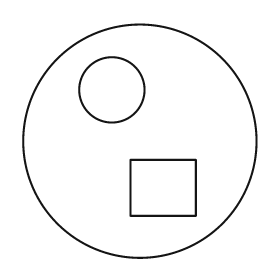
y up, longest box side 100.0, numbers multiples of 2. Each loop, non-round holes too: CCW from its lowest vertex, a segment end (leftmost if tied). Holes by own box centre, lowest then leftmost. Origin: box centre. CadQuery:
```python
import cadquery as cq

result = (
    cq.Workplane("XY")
    .moveTo(0.0, 0.0)
    .circle(50.0)
    .moveTo(-4.0, -32.0)
    .lineTo(24.0, -32.0)
    .lineTo(24.0, -8.0)
    .lineTo(-4.0, -8.0)
    .close()
    .moveTo(-12.0, 22.0)
    .circle(14.0)
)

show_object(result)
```